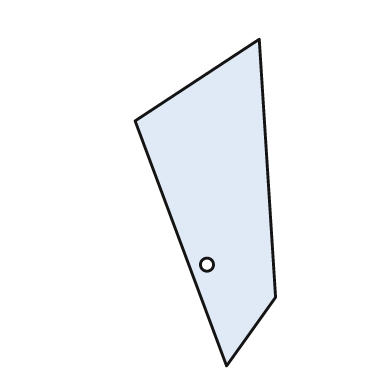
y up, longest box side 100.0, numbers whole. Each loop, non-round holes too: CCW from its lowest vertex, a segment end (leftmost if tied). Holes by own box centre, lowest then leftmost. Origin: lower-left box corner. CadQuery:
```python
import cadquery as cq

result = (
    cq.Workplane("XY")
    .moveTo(28.0, 0.0)
    .lineTo(43.0, 21.0)
    .lineTo(38.0, 100.0)
    .lineTo(0.0, 75.0)
    .close()
    .moveTo(22.0, 31.0)
    .circle(2.0)
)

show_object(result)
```